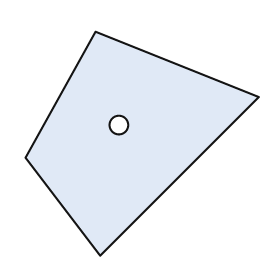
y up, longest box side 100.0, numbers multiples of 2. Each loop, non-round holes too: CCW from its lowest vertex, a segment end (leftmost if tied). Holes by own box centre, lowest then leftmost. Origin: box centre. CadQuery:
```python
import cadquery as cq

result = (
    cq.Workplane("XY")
    .moveTo(-18.0, -48.0)
    .lineTo(50.0, 20.0)
    .lineTo(-20.0, 48.0)
    .lineTo(-50.0, -6.0)
    .close()
    .moveTo(-10.0, 8.0)
    .circle(4.0)
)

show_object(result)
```